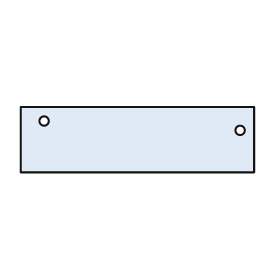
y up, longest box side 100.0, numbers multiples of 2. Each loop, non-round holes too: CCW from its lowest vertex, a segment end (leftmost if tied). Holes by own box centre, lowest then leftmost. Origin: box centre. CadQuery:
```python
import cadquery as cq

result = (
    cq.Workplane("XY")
    .moveTo(-50.0, -14.0)
    .lineTo(50.0, -14.0)
    .lineTo(50.0, 14.0)
    .lineTo(-50.0, 14.0)
    .close()
    .moveTo(44.0, 4.0)
    .circle(2.0)
    .moveTo(-40.0, 8.0)
    .circle(2.0)
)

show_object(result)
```